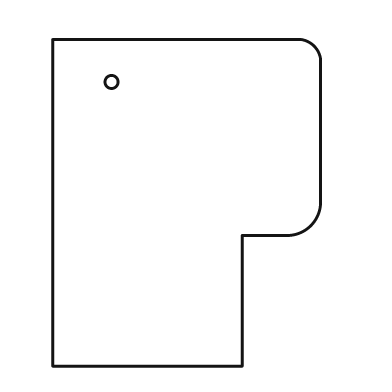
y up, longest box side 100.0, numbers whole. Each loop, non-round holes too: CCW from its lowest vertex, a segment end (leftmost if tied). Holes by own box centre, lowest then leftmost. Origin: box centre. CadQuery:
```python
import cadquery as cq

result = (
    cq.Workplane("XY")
    .moveTo(-41.0, -50.0)
    .lineTo(17.0, -50.0)
    .lineTo(17.0, -10.0)
    .lineTo(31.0, -10.0)
    .threePointArc((38.0, -7.0), (41.0, 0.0))
    .lineTo(41.0, 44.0)
    .threePointArc((39.0, 48.0), (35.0, 50.0))
    .lineTo(-41.0, 50.0)
    .close()
    .moveTo(-23.0, 37.0)
    .circle(2.0)
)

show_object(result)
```